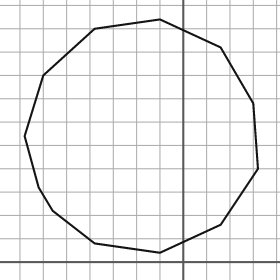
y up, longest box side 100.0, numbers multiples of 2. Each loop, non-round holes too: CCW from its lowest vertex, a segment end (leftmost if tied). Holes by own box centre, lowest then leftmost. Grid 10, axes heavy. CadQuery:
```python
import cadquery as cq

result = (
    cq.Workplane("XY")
    .moveTo(-10.0, 4.0)
    .lineTo(16.0, 16.0)
    .lineTo(32.0, 40.0)
    .lineTo(30.0, 68.0)
    .lineTo(16.0, 92.0)
    .lineTo(-10.0, 104.0)
    .lineTo(-38.0, 100.0)
    .lineTo(-60.0, 80.0)
    .lineTo(-68.0, 54.0)
    .lineTo(-62.0, 32.0)
    .lineTo(-56.0, 22.0)
    .lineTo(-38.0, 8.0)
    .close()
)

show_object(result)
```